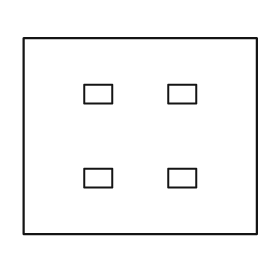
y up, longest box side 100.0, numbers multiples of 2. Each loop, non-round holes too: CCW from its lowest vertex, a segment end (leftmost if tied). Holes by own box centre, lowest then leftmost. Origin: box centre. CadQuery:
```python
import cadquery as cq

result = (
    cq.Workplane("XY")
    .moveTo(-50.0, -42.0)
    .lineTo(50.0, -42.0)
    .lineTo(50.0, 42.0)
    .lineTo(-50.0, 42.0)
    .close()
    .moveTo(-24.0, -22.0)
    .lineTo(-12.0, -22.0)
    .lineTo(-12.0, -14.0)
    .lineTo(-24.0, -14.0)
    .close()
    .moveTo(12.0, -22.0)
    .lineTo(24.0, -22.0)
    .lineTo(24.0, -14.0)
    .lineTo(12.0, -14.0)
    .close()
    .moveTo(-24.0, 14.0)
    .lineTo(-12.0, 14.0)
    .lineTo(-12.0, 22.0)
    .lineTo(-24.0, 22.0)
    .close()
    .moveTo(12.0, 14.0)
    .lineTo(24.0, 14.0)
    .lineTo(24.0, 22.0)
    .lineTo(12.0, 22.0)
    .close()
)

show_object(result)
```